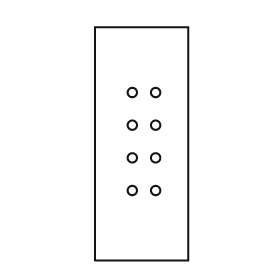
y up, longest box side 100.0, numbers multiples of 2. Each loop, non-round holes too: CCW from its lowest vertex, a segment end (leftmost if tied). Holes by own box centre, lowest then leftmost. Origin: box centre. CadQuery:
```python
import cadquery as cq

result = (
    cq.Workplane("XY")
    .moveTo(-20.0, -50.0)
    .lineTo(20.0, -50.0)
    .lineTo(20.0, 50.0)
    .lineTo(-20.0, 50.0)
    .close()
    .moveTo(-4.0, -20.0)
    .circle(2.0)
    .moveTo(6.0, -20.0)
    .circle(2.0)
    .moveTo(-4.0, -6.0)
    .circle(2.0)
    .moveTo(6.0, -6.0)
    .circle(2.0)
    .moveTo(-4.0, 8.0)
    .circle(2.0)
    .moveTo(6.0, 8.0)
    .circle(2.0)
    .moveTo(-4.0, 22.0)
    .circle(2.0)
    .moveTo(6.0, 22.0)
    .circle(2.0)
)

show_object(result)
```